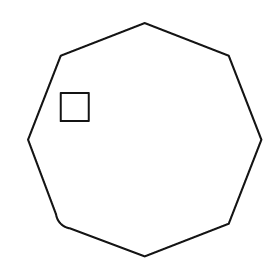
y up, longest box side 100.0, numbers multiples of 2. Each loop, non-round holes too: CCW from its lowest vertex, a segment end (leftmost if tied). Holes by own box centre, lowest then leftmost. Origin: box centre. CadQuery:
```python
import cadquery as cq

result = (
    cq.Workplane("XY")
    .moveTo(0.0, -50.0)
    .lineTo(36.0, -36.0)
    .lineTo(50.0, 0.0)
    .lineTo(36.0, 36.0)
    .lineTo(0.0, 50.0)
    .lineTo(-36.0, 36.0)
    .lineTo(-50.0, 0.0)
    .lineTo(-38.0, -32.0)
    .threePointArc((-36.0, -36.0), (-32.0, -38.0))
    .close()
    .moveTo(-36.0, 8.0)
    .lineTo(-24.0, 8.0)
    .lineTo(-24.0, 20.0)
    .lineTo(-36.0, 20.0)
    .close()
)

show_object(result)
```